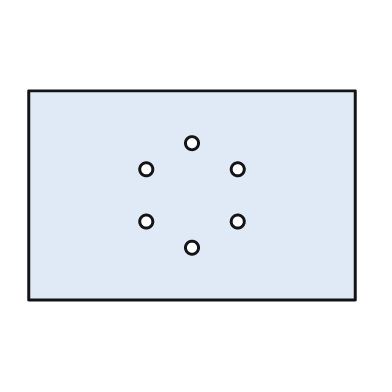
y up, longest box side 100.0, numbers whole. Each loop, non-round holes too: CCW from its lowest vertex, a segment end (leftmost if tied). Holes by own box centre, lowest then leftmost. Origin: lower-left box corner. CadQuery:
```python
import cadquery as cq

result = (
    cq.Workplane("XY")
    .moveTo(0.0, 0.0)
    .lineTo(100.0, 0.0)
    .lineTo(100.0, 64.0)
    .lineTo(0.0, 64.0)
    .close()
    .moveTo(50.0, 16.0)
    .circle(2.0)
    .moveTo(36.0, 24.0)
    .circle(2.0)
    .moveTo(64.0, 24.0)
    .circle(2.0)
    .moveTo(36.0, 40.0)
    .circle(2.0)
    .moveTo(64.0, 40.0)
    .circle(2.0)
    .moveTo(50.0, 48.0)
    .circle(2.0)
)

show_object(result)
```